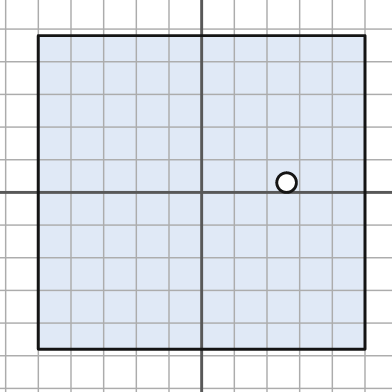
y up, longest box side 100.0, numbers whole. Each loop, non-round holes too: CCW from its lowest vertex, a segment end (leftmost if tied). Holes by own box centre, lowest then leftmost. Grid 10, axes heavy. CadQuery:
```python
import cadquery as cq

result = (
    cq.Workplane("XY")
    .moveTo(-50.0, -48.0)
    .lineTo(50.0, -48.0)
    .lineTo(50.0, 48.0)
    .lineTo(-50.0, 48.0)
    .close()
    .moveTo(26.0, 3.0)
    .circle(3.0)
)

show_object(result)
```